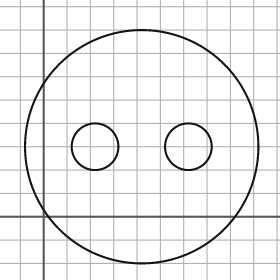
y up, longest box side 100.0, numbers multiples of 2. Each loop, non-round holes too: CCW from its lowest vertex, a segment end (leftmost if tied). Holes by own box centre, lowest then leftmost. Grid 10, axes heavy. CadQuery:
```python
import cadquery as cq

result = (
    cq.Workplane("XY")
    .moveTo(42.0, 30.0)
    .circle(50.0)
    .moveTo(22.0, 30.0)
    .circle(10.0)
    .moveTo(62.0, 30.0)
    .circle(10.0)
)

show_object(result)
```